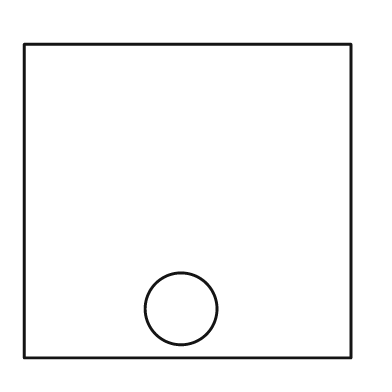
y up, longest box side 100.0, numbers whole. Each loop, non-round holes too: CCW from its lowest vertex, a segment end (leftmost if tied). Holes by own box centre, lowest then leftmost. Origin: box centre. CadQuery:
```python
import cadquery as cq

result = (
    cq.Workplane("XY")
    .moveTo(-50.0, -48.0)
    .lineTo(50.0, -48.0)
    .lineTo(50.0, 48.0)
    .lineTo(-50.0, 48.0)
    .close()
    .moveTo(-2.0, -33.0)
    .circle(11.0)
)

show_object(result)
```